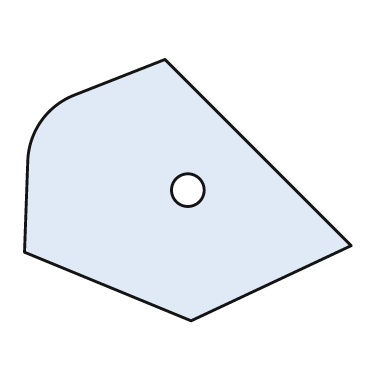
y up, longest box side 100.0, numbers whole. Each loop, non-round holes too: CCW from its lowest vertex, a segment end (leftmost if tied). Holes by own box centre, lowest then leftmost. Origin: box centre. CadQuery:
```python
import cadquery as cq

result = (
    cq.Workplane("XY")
    .moveTo(1.0, -40.0)
    .lineTo(50.0, -17.0)
    .lineTo(-7.0, 40.0)
    .lineTo(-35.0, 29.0)
    .threePointArc((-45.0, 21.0), (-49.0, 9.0))
    .lineTo(-50.0, -19.0)
    .close()
    .moveTo(0.0, 0.0)
    .circle(5.0)
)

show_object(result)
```